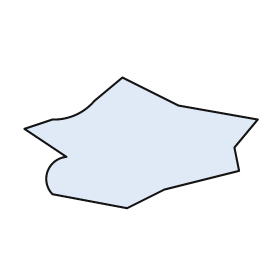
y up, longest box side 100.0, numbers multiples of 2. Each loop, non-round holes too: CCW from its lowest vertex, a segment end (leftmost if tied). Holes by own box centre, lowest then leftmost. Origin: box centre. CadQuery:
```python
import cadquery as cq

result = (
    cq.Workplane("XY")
    .moveTo(-6.0, -28.0)
    .lineTo(10.0, -20.0)
    .lineTo(42.0, -12.0)
    .lineTo(40.0, -2.0)
    .lineTo(50.0, 10.0)
    .lineTo(16.0, 16.0)
    .lineTo(-8.0, 28.0)
    .lineTo(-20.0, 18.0)
    .threePointArc((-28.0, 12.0), (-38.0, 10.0))
    .lineTo(-50.0, 6.0)
    .lineTo(-32.0, -6.0)
    .threePointArc((-40.0, -12.0), (-38.0, -22.0))
    .close()
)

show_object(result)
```